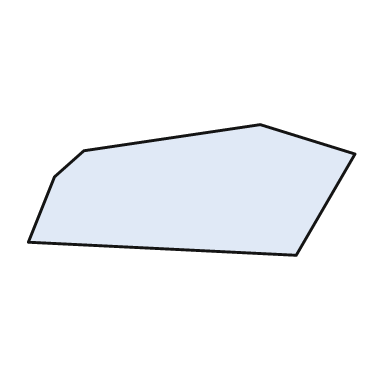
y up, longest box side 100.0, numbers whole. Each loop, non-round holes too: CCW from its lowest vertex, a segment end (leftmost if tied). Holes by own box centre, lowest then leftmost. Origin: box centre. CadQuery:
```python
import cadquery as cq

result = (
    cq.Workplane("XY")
    .moveTo(32.0, -20.0)
    .lineTo(50.0, 11.0)
    .lineTo(21.0, 20.0)
    .lineTo(-33.0, 12.0)
    .lineTo(-42.0, 4.0)
    .lineTo(-50.0, -16.0)
    .close()
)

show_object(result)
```